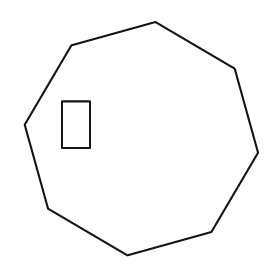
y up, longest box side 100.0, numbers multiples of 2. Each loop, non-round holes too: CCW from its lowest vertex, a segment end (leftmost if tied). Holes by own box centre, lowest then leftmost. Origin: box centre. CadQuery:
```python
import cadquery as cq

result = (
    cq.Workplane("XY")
    .moveTo(-6.0, -50.0)
    .lineTo(30.0, -40.0)
    .lineTo(50.0, -6.0)
    .lineTo(40.0, 30.0)
    .lineTo(6.0, 50.0)
    .lineTo(-30.0, 40.0)
    .lineTo(-50.0, 6.0)
    .lineTo(-40.0, -30.0)
    .close()
    .moveTo(-34.0, -4.0)
    .lineTo(-22.0, -4.0)
    .lineTo(-22.0, 16.0)
    .lineTo(-34.0, 16.0)
    .close()
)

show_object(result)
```